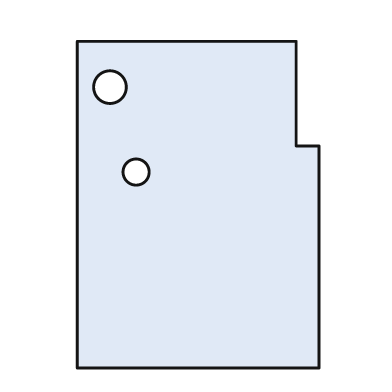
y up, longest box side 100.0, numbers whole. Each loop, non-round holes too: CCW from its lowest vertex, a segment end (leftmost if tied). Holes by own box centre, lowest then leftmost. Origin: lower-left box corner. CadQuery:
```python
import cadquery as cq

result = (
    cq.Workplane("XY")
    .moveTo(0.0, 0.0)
    .lineTo(74.0, 0.0)
    .lineTo(74.0, 68.0)
    .lineTo(67.0, 68.0)
    .lineTo(67.0, 100.0)
    .lineTo(0.0, 100.0)
    .close()
    .moveTo(18.0, 60.0)
    .circle(4.0)
    .moveTo(10.0, 86.0)
    .circle(5.0)
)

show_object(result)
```